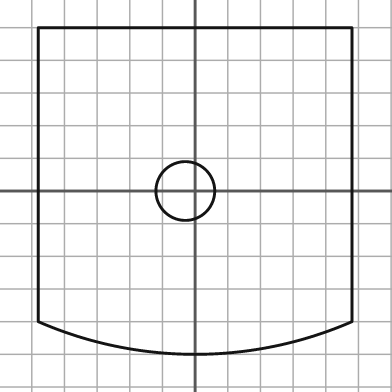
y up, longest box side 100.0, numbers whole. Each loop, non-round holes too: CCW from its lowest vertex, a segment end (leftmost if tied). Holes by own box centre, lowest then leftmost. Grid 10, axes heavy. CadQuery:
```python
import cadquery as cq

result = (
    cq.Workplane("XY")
    .moveTo(-48.0, -40.0)
    .threePointArc((0.0, -50.0), (48.0, -40.0))
    .lineTo(48.0, 50.0)
    .lineTo(-48.0, 50.0)
    .close()
    .moveTo(-3.0, 0.0)
    .circle(9.0)
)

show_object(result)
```